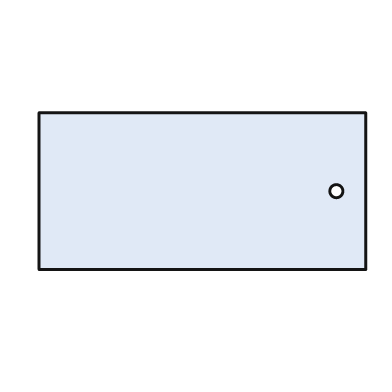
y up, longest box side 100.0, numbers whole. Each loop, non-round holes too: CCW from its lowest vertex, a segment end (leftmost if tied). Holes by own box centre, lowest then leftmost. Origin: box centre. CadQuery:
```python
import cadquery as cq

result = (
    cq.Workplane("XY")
    .moveTo(-50.0, -24.0)
    .lineTo(50.0, -24.0)
    .lineTo(50.0, 24.0)
    .lineTo(-50.0, 24.0)
    .close()
    .moveTo(41.0, 0.0)
    .circle(2.0)
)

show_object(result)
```